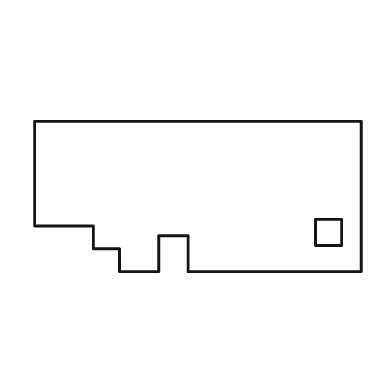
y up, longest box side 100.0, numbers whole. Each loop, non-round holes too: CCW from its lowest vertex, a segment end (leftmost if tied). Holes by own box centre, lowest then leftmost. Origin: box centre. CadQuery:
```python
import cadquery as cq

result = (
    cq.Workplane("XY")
    .moveTo(-24.0, -23.0)
    .lineTo(-12.0, -23.0)
    .lineTo(-12.0, -12.0)
    .lineTo(-3.0, -12.0)
    .lineTo(-3.0, -23.0)
    .lineTo(50.0, -23.0)
    .lineTo(50.0, 23.0)
    .lineTo(-50.0, 23.0)
    .lineTo(-50.0, -9.0)
    .lineTo(-32.0, -9.0)
    .lineTo(-32.0, -16.0)
    .lineTo(-24.0, -16.0)
    .close()
    .moveTo(36.0, -15.0)
    .lineTo(44.0, -15.0)
    .lineTo(44.0, -7.0)
    .lineTo(36.0, -7.0)
    .close()
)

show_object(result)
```